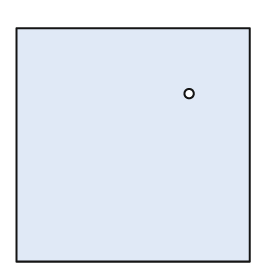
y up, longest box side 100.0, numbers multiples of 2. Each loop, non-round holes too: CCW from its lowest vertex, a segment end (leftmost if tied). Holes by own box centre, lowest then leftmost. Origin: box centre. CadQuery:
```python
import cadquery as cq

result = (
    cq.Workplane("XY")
    .moveTo(-50.0, -50.0)
    .lineTo(50.0, -50.0)
    .lineTo(50.0, 50.0)
    .lineTo(-50.0, 50.0)
    .close()
    .moveTo(24.0, 22.0)
    .circle(2.0)
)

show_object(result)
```